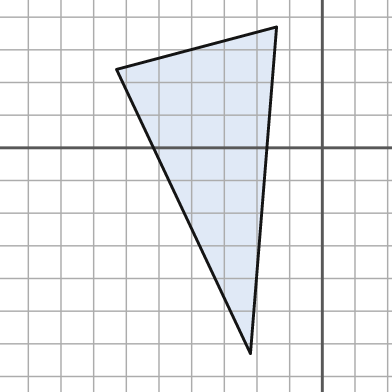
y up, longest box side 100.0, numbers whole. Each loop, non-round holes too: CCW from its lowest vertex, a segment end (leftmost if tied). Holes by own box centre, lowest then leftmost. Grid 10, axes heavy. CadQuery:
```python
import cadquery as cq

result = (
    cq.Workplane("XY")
    .moveTo(-22.0, -63.0)
    .lineTo(-14.0, 37.0)
    .lineTo(-63.0, 24.0)
    .close()
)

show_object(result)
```